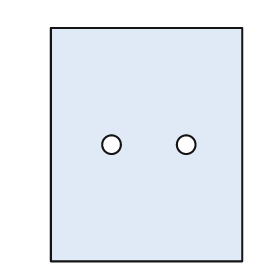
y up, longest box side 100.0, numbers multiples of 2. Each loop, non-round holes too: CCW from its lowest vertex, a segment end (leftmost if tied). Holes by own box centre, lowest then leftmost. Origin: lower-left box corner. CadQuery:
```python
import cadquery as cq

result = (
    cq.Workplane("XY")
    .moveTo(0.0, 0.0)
    .lineTo(82.0, 0.0)
    .lineTo(82.0, 100.0)
    .lineTo(0.0, 100.0)
    .close()
    .moveTo(26.0, 50.0)
    .circle(4.0)
    .moveTo(58.0, 50.0)
    .circle(4.0)
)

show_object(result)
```